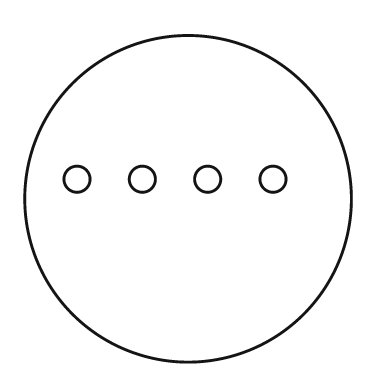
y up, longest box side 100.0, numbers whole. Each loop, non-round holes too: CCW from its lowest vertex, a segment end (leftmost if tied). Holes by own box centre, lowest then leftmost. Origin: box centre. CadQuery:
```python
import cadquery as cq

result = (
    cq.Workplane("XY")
    .moveTo(0.0, 0.0)
    .circle(50.0)
    .moveTo(-34.0, 6.0)
    .circle(4.0)
    .moveTo(-14.0, 6.0)
    .circle(4.0)
    .moveTo(6.0, 6.0)
    .circle(4.0)
    .moveTo(26.0, 6.0)
    .circle(4.0)
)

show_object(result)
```